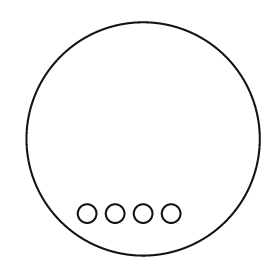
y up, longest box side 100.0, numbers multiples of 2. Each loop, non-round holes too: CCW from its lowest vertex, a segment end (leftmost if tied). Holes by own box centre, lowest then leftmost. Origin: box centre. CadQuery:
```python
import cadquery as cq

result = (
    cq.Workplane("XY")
    .moveTo(0.0, 0.0)
    .circle(50.0)
    .moveTo(-24.0, -32.0)
    .circle(4.0)
    .moveTo(-12.0, -32.0)
    .circle(4.0)
    .moveTo(0.0, -32.0)
    .circle(4.0)
    .moveTo(12.0, -32.0)
    .circle(4.0)
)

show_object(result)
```